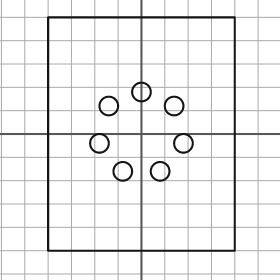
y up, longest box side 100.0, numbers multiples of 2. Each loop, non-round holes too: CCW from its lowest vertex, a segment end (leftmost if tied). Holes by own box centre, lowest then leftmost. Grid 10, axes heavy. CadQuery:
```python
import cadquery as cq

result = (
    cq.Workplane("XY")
    .moveTo(-40.0, -50.0)
    .lineTo(40.0, -50.0)
    .lineTo(40.0, 50.0)
    .lineTo(-40.0, 50.0)
    .close()
    .moveTo(-8.0, -16.0)
    .circle(4.0)
    .moveTo(8.0, -16.0)
    .circle(4.0)
    .moveTo(-18.0, -4.0)
    .circle(4.0)
    .moveTo(18.0, -4.0)
    .circle(4.0)
    .moveTo(-14.0, 12.0)
    .circle(4.0)
    .moveTo(14.0, 12.0)
    .circle(4.0)
    .moveTo(0.0, 18.0)
    .circle(4.0)
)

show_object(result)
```